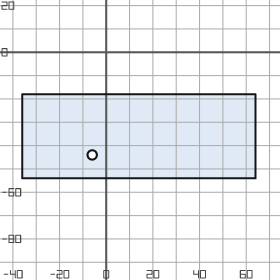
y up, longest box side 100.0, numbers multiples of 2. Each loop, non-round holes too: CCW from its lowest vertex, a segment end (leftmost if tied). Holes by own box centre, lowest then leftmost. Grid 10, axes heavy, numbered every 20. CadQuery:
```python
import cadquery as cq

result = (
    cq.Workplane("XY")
    .moveTo(-36.0, -54.0)
    .lineTo(64.0, -54.0)
    .lineTo(64.0, -18.0)
    .lineTo(-36.0, -18.0)
    .close()
    .moveTo(-6.0, -44.0)
    .circle(2.0)
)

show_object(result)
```